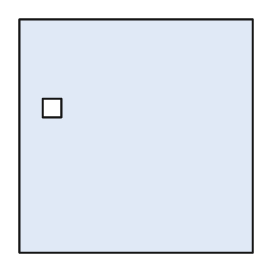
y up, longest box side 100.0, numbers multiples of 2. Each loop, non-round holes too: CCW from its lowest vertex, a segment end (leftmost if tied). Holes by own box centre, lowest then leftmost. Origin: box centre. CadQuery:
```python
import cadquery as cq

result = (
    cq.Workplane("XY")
    .moveTo(-50.0, -50.0)
    .lineTo(50.0, -50.0)
    .lineTo(50.0, 50.0)
    .lineTo(-50.0, 50.0)
    .close()
    .moveTo(-40.0, 8.0)
    .lineTo(-32.0, 8.0)
    .lineTo(-32.0, 16.0)
    .lineTo(-40.0, 16.0)
    .close()
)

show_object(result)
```